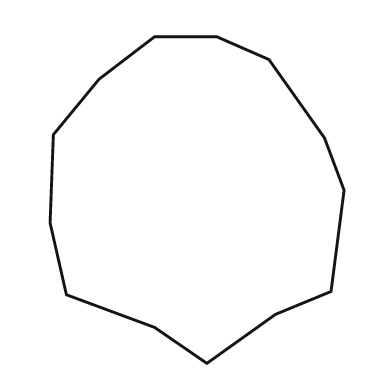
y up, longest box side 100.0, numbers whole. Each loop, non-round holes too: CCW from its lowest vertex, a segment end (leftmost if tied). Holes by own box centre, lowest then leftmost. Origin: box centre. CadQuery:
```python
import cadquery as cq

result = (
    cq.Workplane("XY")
    .moveTo(3.0, -50.0)
    .lineTo(24.0, -35.0)
    .lineTo(41.0, -28.0)
    .lineTo(45.0, 3.0)
    .lineTo(39.0, 19.0)
    .lineTo(22.0, 43.0)
    .lineTo(6.0, 50.0)
    .lineTo(-13.0, 50.0)
    .lineTo(-30.0, 37.0)
    .lineTo(-44.0, 20.0)
    .lineTo(-45.0, -7.0)
    .lineTo(-40.0, -29.0)
    .lineTo(-13.0, -39.0)
    .close()
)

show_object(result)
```